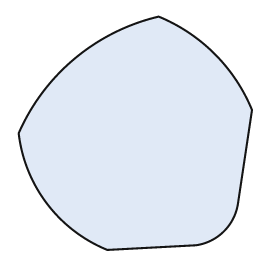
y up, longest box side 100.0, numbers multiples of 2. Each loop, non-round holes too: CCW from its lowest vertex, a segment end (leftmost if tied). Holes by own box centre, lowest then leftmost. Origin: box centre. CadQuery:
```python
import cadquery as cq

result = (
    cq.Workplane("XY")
    .moveTo(-12.0, -50.0)
    .lineTo(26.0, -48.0)
    .threePointArc((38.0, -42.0), (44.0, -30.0))
    .lineTo(50.0, 10.0)
    .threePointArc((34.0, 34.0), (10.0, 50.0))
    .threePointArc((-26.0, 32.0), (-50.0, 0.0))
    .threePointArc((-38.0, -30.0), (-12.0, -50.0))
    .close()
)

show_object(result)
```